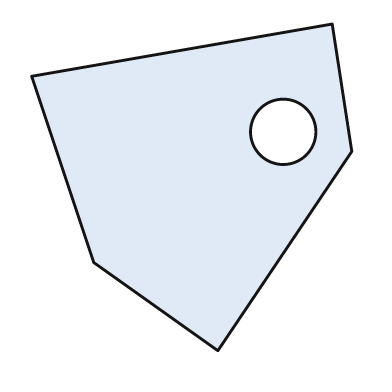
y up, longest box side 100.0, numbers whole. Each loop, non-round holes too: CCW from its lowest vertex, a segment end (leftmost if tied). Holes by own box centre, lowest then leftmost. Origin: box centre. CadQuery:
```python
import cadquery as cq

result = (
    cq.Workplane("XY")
    .moveTo(8.0, -50.0)
    .lineTo(49.0, 11.0)
    .lineTo(43.0, 50.0)
    .lineTo(-49.0, 34.0)
    .lineTo(-30.0, -23.0)
    .close()
    .moveTo(28.0, 17.0)
    .circle(10.0)
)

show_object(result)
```